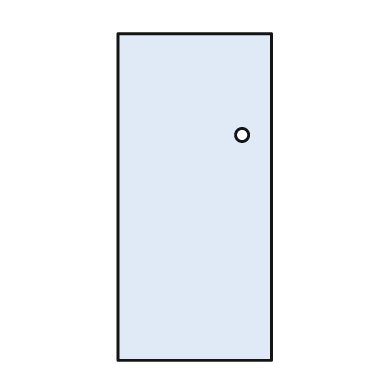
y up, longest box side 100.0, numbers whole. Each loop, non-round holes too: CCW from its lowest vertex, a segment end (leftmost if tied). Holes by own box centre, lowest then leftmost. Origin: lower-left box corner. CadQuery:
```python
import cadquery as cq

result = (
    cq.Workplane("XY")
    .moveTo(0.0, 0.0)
    .lineTo(47.0, 0.0)
    .lineTo(47.0, 100.0)
    .lineTo(0.0, 100.0)
    .close()
    .moveTo(38.0, 69.0)
    .circle(2.0)
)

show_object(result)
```